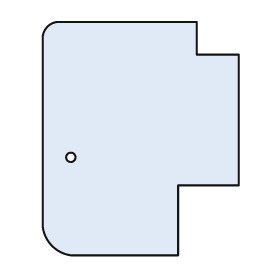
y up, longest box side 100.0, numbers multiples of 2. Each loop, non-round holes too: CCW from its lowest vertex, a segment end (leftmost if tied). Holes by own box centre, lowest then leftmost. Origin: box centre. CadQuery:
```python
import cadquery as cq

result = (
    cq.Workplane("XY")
    .moveTo(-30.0, -50.0)
    .lineTo(16.0, -50.0)
    .lineTo(16.0, -20.0)
    .lineTo(42.0, -20.0)
    .lineTo(42.0, 36.0)
    .lineTo(24.0, 36.0)
    .lineTo(24.0, 50.0)
    .lineTo(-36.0, 50.0)
    .threePointArc((-40.0, 48.0), (-42.0, 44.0))
    .lineTo(-42.0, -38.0)
    .threePointArc((-38.0, -46.0), (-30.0, -50.0))
    .close()
    .moveTo(-30.0, -8.0)
    .circle(2.0)
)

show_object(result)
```